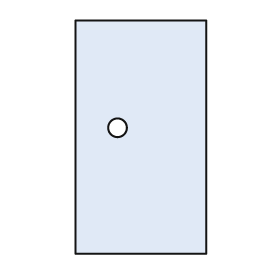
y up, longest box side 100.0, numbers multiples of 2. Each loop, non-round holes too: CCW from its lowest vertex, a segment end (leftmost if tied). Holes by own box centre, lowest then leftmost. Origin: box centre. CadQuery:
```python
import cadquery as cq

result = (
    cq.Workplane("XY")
    .moveTo(-28.0, -50.0)
    .lineTo(28.0, -50.0)
    .lineTo(28.0, 50.0)
    .lineTo(-28.0, 50.0)
    .close()
    .moveTo(-10.0, 4.0)
    .circle(4.0)
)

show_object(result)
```